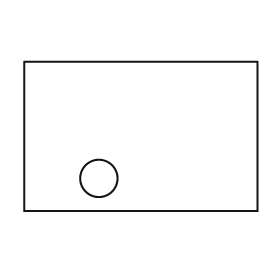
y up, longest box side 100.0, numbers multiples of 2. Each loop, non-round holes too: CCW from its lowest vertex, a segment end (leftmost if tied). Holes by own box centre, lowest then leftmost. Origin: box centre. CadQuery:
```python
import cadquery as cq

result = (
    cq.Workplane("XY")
    .moveTo(-50.0, -32.0)
    .lineTo(50.0, -32.0)
    .lineTo(50.0, 32.0)
    .lineTo(-50.0, 32.0)
    .close()
    .moveTo(-18.0, -18.0)
    .circle(8.0)
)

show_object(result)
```